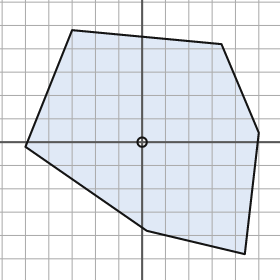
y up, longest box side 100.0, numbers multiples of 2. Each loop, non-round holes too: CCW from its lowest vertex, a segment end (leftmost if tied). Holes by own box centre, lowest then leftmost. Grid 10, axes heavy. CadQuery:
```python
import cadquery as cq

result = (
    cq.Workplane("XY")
    .moveTo(44.0, -48.0)
    .lineTo(50.0, 4.0)
    .lineTo(34.0, 42.0)
    .lineTo(-30.0, 48.0)
    .lineTo(-50.0, -2.0)
    .lineTo(2.0, -38.0)
    .close()
    .moveTo(0.0, 0.0)
    .circle(2.0)
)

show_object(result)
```